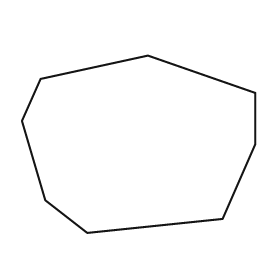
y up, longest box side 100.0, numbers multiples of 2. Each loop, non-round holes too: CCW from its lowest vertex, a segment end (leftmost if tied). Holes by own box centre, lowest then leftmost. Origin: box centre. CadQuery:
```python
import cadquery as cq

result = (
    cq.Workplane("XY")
    .moveTo(-22.0, -38.0)
    .lineTo(36.0, -32.0)
    .lineTo(50.0, 0.0)
    .lineTo(50.0, 22.0)
    .lineTo(4.0, 38.0)
    .lineTo(-42.0, 28.0)
    .lineTo(-50.0, 10.0)
    .lineTo(-40.0, -24.0)
    .close()
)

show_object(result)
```